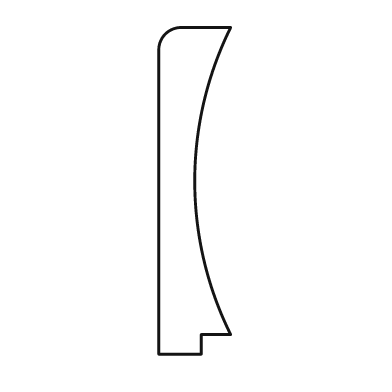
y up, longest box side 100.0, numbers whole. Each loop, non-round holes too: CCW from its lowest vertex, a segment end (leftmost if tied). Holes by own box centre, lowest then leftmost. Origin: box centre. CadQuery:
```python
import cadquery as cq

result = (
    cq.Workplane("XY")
    .moveTo(-11.0, -50.0)
    .lineTo(2.0, -50.0)
    .lineTo(2.0, -44.0)
    .lineTo(11.0, -44.0)
    .threePointArc((0.0, 3.0), (11.0, 50.0))
    .lineTo(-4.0, 50.0)
    .threePointArc((-9.0, 48.0), (-11.0, 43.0))
    .close()
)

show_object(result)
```